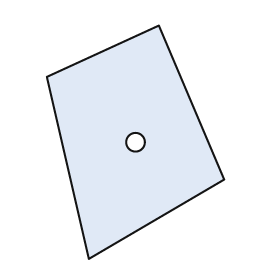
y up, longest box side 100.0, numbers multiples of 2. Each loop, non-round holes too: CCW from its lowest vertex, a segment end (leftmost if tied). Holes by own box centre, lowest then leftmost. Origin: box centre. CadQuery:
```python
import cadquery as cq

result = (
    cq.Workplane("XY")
    .moveTo(-20.0, -50.0)
    .lineTo(38.0, -16.0)
    .lineTo(10.0, 50.0)
    .lineTo(-38.0, 28.0)
    .close()
    .moveTo(0.0, 0.0)
    .circle(4.0)
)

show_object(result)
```